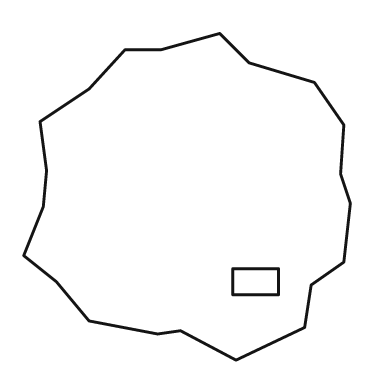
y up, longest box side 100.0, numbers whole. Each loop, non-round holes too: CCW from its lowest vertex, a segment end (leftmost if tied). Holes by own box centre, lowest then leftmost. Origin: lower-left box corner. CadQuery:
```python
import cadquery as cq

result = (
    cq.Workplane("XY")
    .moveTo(65.0, 0.0)
    .lineTo(86.0, 10.0)
    .lineTo(88.0, 23.0)
    .lineTo(98.0, 30.0)
    .lineTo(100.0, 48.0)
    .lineTo(97.0, 57.0)
    .lineTo(98.0, 72.0)
    .lineTo(89.0, 85.0)
    .lineTo(69.0, 91.0)
    .lineTo(60.0, 100.0)
    .lineTo(42.0, 95.0)
    .lineTo(31.0, 95.0)
    .lineTo(20.0, 83.0)
    .lineTo(5.0, 73.0)
    .lineTo(7.0, 58.0)
    .lineTo(6.0, 47.0)
    .lineTo(0.0, 32.0)
    .lineTo(10.0, 24.0)
    .lineTo(20.0, 12.0)
    .lineTo(41.0, 8.0)
    .lineTo(48.0, 9.0)
    .close()
    .moveTo(64.0, 20.0)
    .lineTo(78.0, 20.0)
    .lineTo(78.0, 28.0)
    .lineTo(64.0, 28.0)
    .close()
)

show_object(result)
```